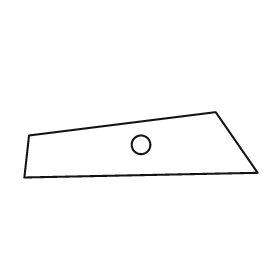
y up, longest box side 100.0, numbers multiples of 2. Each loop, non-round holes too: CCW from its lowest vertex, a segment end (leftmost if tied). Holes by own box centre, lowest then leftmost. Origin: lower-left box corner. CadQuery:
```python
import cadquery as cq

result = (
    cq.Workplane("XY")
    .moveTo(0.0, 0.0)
    .lineTo(100.0, 2.0)
    .lineTo(82.0, 28.0)
    .lineTo(2.0, 18.0)
    .close()
    .moveTo(50.0, 14.0)
    .circle(4.0)
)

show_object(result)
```